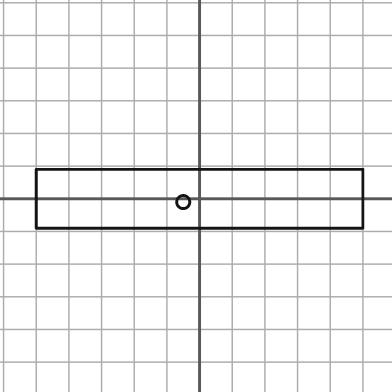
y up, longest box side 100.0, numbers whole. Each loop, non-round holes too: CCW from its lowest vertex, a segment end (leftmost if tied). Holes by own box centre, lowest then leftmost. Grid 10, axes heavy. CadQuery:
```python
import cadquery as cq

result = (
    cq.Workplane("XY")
    .moveTo(-50.0, -9.0)
    .lineTo(50.0, -9.0)
    .lineTo(50.0, 9.0)
    .lineTo(-50.0, 9.0)
    .close()
    .moveTo(-5.0, -1.0)
    .circle(2.0)
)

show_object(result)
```